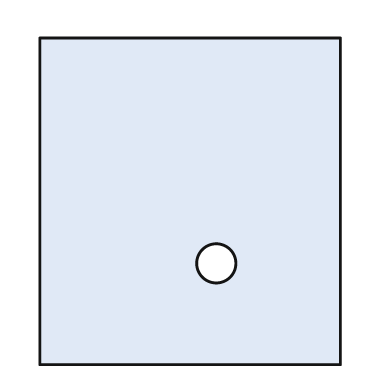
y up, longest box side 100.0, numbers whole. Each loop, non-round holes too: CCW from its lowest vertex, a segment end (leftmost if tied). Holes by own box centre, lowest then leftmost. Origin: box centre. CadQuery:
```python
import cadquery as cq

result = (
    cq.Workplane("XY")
    .moveTo(-46.0, -50.0)
    .lineTo(46.0, -50.0)
    .lineTo(46.0, 50.0)
    .lineTo(-46.0, 50.0)
    .close()
    .moveTo(8.0, -19.0)
    .circle(6.0)
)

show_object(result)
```